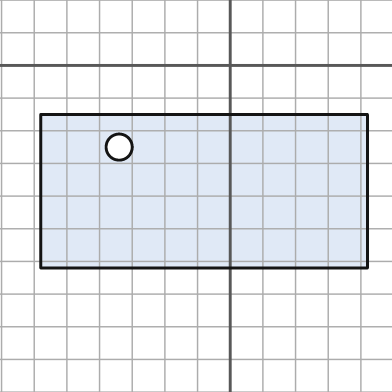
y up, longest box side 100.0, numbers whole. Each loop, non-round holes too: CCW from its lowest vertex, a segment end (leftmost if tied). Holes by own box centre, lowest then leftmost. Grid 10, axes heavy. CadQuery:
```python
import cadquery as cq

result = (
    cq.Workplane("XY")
    .moveTo(-58.0, -62.0)
    .lineTo(42.0, -62.0)
    .lineTo(42.0, -15.0)
    .lineTo(-58.0, -15.0)
    .close()
    .moveTo(-34.0, -25.0)
    .circle(4.0)
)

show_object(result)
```